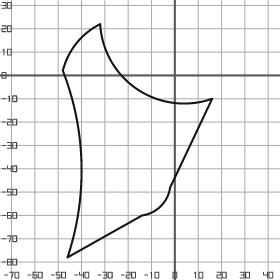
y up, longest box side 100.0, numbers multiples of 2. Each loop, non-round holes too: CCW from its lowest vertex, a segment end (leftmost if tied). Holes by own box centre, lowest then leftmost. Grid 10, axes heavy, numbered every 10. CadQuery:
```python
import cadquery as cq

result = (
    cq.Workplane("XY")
    .moveTo(-46.0, -78.0)
    .lineTo(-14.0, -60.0)
    .threePointArc((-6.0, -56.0), (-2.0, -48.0))
    .lineTo(16.0, -10.0)
    .threePointArc((-16.0, -6.0), (-32.0, 22.0))
    .threePointArc((-42.0, 14.0), (-48.0, 2.0))
    .threePointArc((-40.0, -38.0), (-46.0, -78.0))
    .close()
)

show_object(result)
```